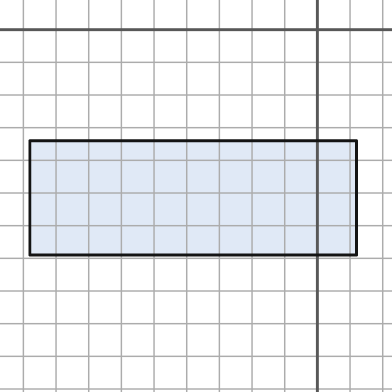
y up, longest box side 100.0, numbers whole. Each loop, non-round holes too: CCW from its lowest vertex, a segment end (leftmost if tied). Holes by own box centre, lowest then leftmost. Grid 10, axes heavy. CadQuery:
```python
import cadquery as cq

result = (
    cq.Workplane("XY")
    .moveTo(-88.0, -69.0)
    .lineTo(12.0, -69.0)
    .lineTo(12.0, -34.0)
    .lineTo(-88.0, -34.0)
    .close()
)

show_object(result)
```